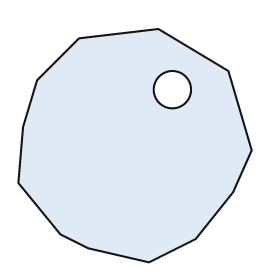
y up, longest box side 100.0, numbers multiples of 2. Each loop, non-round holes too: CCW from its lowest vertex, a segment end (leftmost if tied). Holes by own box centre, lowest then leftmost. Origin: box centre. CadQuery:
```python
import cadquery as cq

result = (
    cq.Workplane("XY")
    .moveTo(6.0, -50.0)
    .lineTo(26.0, -40.0)
    .lineTo(42.0, -20.0)
    .lineTo(50.0, -2.0)
    .lineTo(40.0, 32.0)
    .lineTo(10.0, 50.0)
    .lineTo(-24.0, 46.0)
    .lineTo(-42.0, 28.0)
    .lineTo(-48.0, 8.0)
    .lineTo(-50.0, -16.0)
    .lineTo(-32.0, -38.0)
    .lineTo(-20.0, -44.0)
    .close()
    .moveTo(16.0, 24.0)
    .circle(8.0)
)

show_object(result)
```